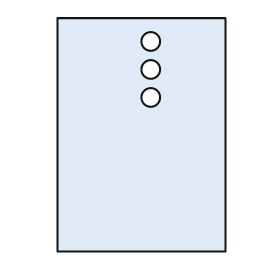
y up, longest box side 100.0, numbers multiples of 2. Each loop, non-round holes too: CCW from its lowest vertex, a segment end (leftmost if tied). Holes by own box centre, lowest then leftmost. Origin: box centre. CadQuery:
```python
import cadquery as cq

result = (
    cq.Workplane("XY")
    .moveTo(-36.0, -50.0)
    .lineTo(36.0, -50.0)
    .lineTo(36.0, 50.0)
    .lineTo(-36.0, 50.0)
    .close()
    .moveTo(4.0, 16.0)
    .circle(4.0)
    .moveTo(4.0, 28.0)
    .circle(4.0)
    .moveTo(4.0, 40.0)
    .circle(4.0)
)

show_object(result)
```